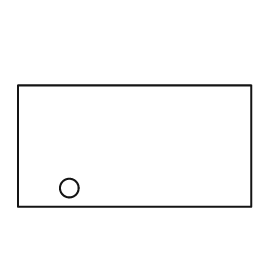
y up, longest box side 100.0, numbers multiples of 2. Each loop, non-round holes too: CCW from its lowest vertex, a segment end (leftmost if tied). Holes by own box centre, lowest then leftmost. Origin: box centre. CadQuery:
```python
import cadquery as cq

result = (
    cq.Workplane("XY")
    .moveTo(-50.0, -26.0)
    .lineTo(50.0, -26.0)
    .lineTo(50.0, 26.0)
    .lineTo(-50.0, 26.0)
    .close()
    .moveTo(-28.0, -18.0)
    .circle(4.0)
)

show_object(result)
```